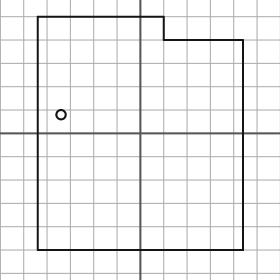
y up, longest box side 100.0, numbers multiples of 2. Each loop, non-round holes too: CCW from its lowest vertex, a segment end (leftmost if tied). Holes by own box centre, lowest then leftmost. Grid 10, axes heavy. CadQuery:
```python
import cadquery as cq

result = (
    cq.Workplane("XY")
    .moveTo(-44.0, -50.0)
    .lineTo(44.0, -50.0)
    .lineTo(44.0, 40.0)
    .lineTo(10.0, 40.0)
    .lineTo(10.0, 50.0)
    .lineTo(-44.0, 50.0)
    .close()
    .moveTo(-34.0, 8.0)
    .circle(2.0)
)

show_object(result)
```